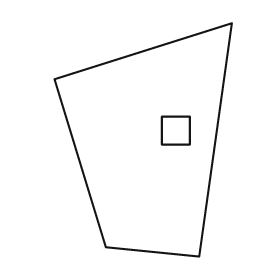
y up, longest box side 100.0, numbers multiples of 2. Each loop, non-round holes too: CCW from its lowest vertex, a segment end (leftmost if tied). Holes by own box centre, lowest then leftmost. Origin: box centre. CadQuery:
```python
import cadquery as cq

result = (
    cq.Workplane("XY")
    .moveTo(24.0, -50.0)
    .lineTo(38.0, 50.0)
    .lineTo(-38.0, 26.0)
    .lineTo(-16.0, -46.0)
    .close()
    .moveTo(8.0, -2.0)
    .lineTo(20.0, -2.0)
    .lineTo(20.0, 10.0)
    .lineTo(8.0, 10.0)
    .close()
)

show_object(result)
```